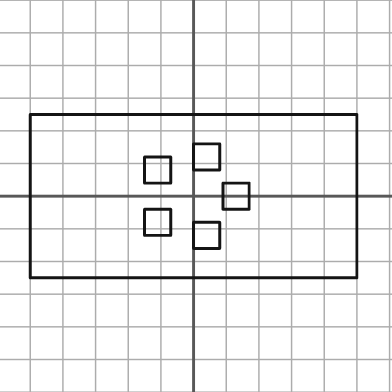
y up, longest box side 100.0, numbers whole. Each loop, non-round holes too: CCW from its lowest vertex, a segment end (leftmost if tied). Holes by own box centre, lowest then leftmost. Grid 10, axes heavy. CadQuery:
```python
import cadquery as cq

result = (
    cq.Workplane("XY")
    .moveTo(-50.0, -25.0)
    .lineTo(50.0, -25.0)
    .lineTo(50.0, 25.0)
    .lineTo(-50.0, 25.0)
    .close()
    .moveTo(0.0, -16.0)
    .lineTo(8.0, -16.0)
    .lineTo(8.0, -8.0)
    .lineTo(0.0, -8.0)
    .close()
    .moveTo(-15.0, -12.0)
    .lineTo(-7.0, -12.0)
    .lineTo(-7.0, -4.0)
    .lineTo(-15.0, -4.0)
    .close()
    .moveTo(9.0, -4.0)
    .lineTo(17.0, -4.0)
    .lineTo(17.0, 4.0)
    .lineTo(9.0, 4.0)
    .close()
    .moveTo(-15.0, 4.0)
    .lineTo(-7.0, 4.0)
    .lineTo(-7.0, 12.0)
    .lineTo(-15.0, 12.0)
    .close()
    .moveTo(0.0, 8.0)
    .lineTo(8.0, 8.0)
    .lineTo(8.0, 16.0)
    .lineTo(0.0, 16.0)
    .close()
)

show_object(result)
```